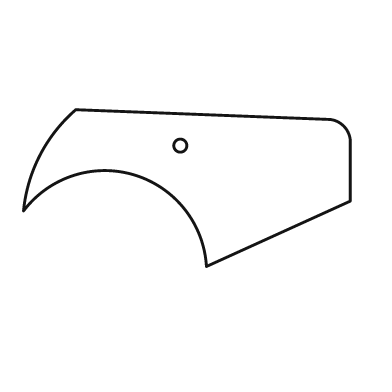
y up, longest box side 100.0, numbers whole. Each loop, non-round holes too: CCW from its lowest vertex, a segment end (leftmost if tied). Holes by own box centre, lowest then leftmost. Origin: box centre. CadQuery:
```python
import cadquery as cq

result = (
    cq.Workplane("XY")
    .moveTo(6.0, -24.0)
    .lineTo(50.0, -4.0)
    .lineTo(50.0, 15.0)
    .threePointArc((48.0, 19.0), (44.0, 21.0))
    .lineTo(-34.0, 24.0)
    .threePointArc((-45.0, 10.0), (-50.0, -7.0))
    .threePointArc((-16.0, 4.0), (6.0, -24.0))
    .close()
    .moveTo(-2.0, 13.0)
    .circle(2.0)
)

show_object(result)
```